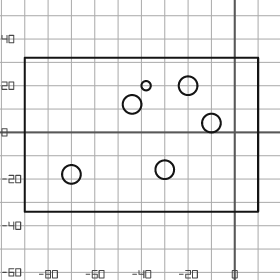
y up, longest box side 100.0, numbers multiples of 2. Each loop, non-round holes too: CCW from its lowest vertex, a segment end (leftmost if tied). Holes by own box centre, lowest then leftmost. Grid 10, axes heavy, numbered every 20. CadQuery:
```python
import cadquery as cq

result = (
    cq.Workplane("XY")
    .moveTo(-90.0, -34.0)
    .lineTo(10.0, -34.0)
    .lineTo(10.0, 32.0)
    .lineTo(-90.0, 32.0)
    .close()
    .moveTo(-70.0, -18.0)
    .circle(4.0)
    .moveTo(-30.0, -16.0)
    .circle(4.0)
    .moveTo(-10.0, 4.0)
    .circle(4.0)
    .moveTo(-44.0, 12.0)
    .circle(4.0)
    .moveTo(-38.0, 20.0)
    .circle(2.0)
    .moveTo(-20.0, 20.0)
    .circle(4.0)
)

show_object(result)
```